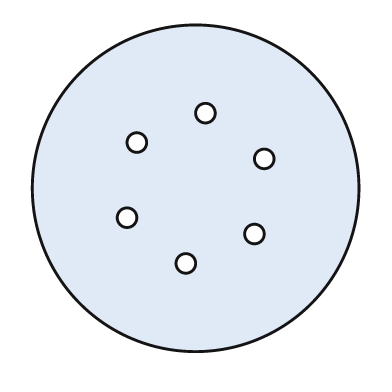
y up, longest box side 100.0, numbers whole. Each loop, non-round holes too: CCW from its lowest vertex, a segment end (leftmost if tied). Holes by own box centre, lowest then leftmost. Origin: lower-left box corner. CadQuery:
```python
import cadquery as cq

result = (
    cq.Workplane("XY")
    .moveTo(50.0, 50.0)
    .circle(50.0)
    .moveTo(47.0, 27.0)
    .circle(3.0)
    .moveTo(68.0, 36.0)
    .circle(3.0)
    .moveTo(29.0, 41.0)
    .circle(3.0)
    .moveTo(71.0, 59.0)
    .circle(3.0)
    .moveTo(32.0, 64.0)
    .circle(3.0)
    .moveTo(53.0, 73.0)
    .circle(3.0)
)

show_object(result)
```